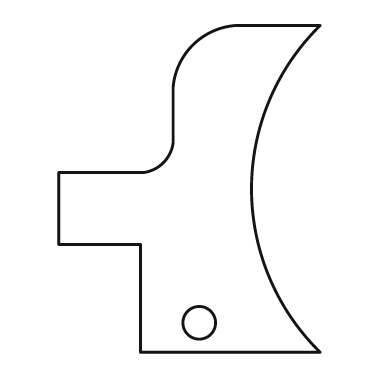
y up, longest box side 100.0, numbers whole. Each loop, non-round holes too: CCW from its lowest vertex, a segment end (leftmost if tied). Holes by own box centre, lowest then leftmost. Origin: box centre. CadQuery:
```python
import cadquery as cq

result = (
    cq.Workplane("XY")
    .moveTo(-15.0, -50.0)
    .lineTo(40.0, -50.0)
    .threePointArc((19.0, 0.0), (40.0, 50.0))
    .lineTo(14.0, 50.0)
    .threePointArc((1.0, 44.0), (-5.0, 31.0))
    .lineTo(-5.0, 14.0)
    .threePointArc((-8.0, 8.0), (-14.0, 5.0))
    .lineTo(-40.0, 5.0)
    .lineTo(-40.0, -17.0)
    .lineTo(-15.0, -17.0)
    .close()
    .moveTo(3.0, -41.0)
    .circle(5.0)
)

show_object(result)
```